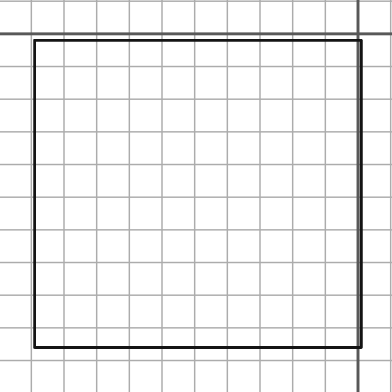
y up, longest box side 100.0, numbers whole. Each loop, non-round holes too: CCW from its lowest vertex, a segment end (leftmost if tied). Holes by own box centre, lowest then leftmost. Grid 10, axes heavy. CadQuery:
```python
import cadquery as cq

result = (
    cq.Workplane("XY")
    .moveTo(-99.0, -96.0)
    .lineTo(1.0, -96.0)
    .lineTo(1.0, -2.0)
    .lineTo(-99.0, -2.0)
    .close()
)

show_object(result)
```